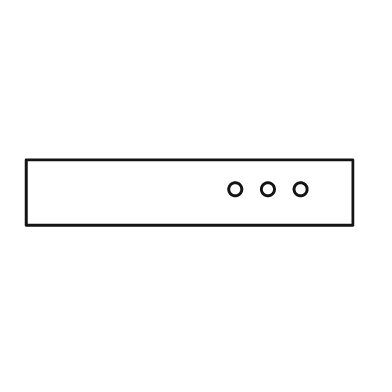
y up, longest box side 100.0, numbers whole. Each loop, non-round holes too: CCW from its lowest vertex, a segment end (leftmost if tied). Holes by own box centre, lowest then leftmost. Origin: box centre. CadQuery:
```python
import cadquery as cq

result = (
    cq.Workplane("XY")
    .moveTo(-50.0, -10.0)
    .lineTo(50.0, -10.0)
    .lineTo(50.0, 10.0)
    .lineTo(-50.0, 10.0)
    .close()
    .moveTo(14.0, 1.0)
    .circle(2.0)
    .moveTo(24.0, 1.0)
    .circle(2.0)
    .moveTo(34.0, 1.0)
    .circle(2.0)
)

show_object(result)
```